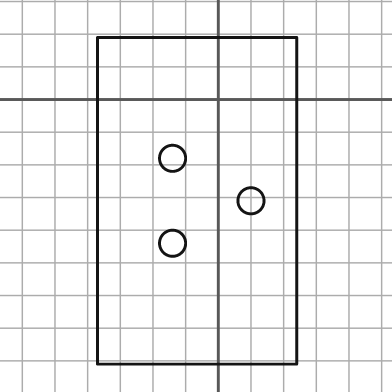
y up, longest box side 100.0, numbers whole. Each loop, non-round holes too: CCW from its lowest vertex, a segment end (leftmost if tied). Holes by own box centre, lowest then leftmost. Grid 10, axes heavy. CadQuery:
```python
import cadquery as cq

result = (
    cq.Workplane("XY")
    .moveTo(-37.0, -81.0)
    .lineTo(24.0, -81.0)
    .lineTo(24.0, 19.0)
    .lineTo(-37.0, 19.0)
    .close()
    .moveTo(-14.0, -44.0)
    .circle(4.0)
    .moveTo(10.0, -31.0)
    .circle(4.0)
    .moveTo(-14.0, -18.0)
    .circle(4.0)
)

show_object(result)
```